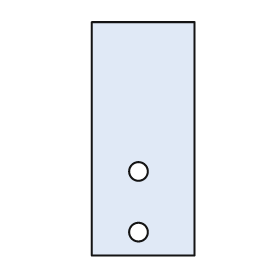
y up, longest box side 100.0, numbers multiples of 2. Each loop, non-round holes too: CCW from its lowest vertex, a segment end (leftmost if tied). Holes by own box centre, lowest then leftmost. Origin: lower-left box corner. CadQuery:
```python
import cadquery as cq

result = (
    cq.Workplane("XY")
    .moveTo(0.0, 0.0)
    .lineTo(44.0, 0.0)
    .lineTo(44.0, 100.0)
    .lineTo(0.0, 100.0)
    .close()
    .moveTo(20.0, 10.0)
    .circle(4.0)
    .moveTo(20.0, 36.0)
    .circle(4.0)
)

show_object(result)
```